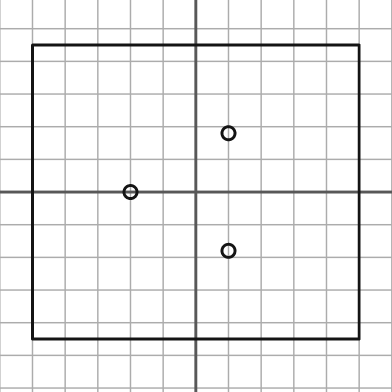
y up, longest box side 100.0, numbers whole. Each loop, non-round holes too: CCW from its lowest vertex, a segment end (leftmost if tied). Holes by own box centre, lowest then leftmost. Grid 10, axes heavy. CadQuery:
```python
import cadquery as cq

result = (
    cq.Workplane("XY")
    .moveTo(-50.0, -45.0)
    .lineTo(50.0, -45.0)
    .lineTo(50.0, 45.0)
    .lineTo(-50.0, 45.0)
    .close()
    .moveTo(10.0, -18.0)
    .circle(2.0)
    .moveTo(-20.0, 0.0)
    .circle(2.0)
    .moveTo(10.0, 18.0)
    .circle(2.0)
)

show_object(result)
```